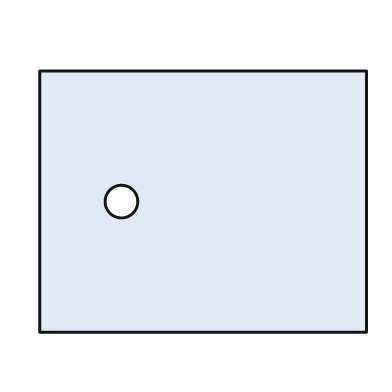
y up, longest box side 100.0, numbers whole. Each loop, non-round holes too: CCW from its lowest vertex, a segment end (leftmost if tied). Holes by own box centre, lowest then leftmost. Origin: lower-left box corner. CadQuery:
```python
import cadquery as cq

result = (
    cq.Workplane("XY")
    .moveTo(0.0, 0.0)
    .lineTo(100.0, 0.0)
    .lineTo(100.0, 80.0)
    .lineTo(0.0, 80.0)
    .close()
    .moveTo(25.0, 40.0)
    .circle(5.0)
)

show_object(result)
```